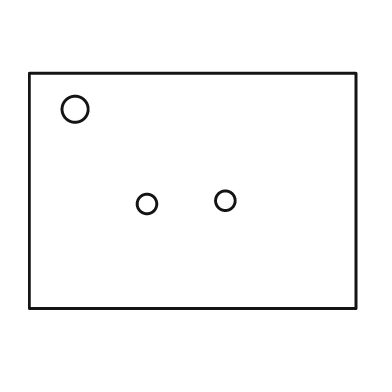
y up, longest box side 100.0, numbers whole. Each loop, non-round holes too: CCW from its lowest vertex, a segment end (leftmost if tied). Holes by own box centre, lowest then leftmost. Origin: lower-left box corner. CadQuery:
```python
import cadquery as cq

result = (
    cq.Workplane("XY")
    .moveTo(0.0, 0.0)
    .lineTo(100.0, 0.0)
    .lineTo(100.0, 72.0)
    .lineTo(0.0, 72.0)
    .close()
    .moveTo(36.0, 32.0)
    .circle(3.0)
    .moveTo(60.0, 33.0)
    .circle(3.0)
    .moveTo(14.0, 61.0)
    .circle(4.0)
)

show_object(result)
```